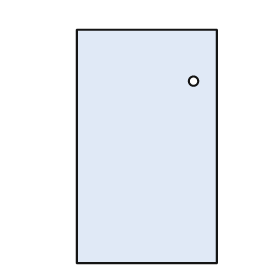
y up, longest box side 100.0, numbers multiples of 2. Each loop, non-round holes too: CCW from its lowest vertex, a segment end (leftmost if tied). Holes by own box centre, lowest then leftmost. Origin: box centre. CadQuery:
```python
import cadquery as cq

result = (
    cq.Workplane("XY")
    .moveTo(-30.0, -50.0)
    .lineTo(30.0, -50.0)
    .lineTo(30.0, 50.0)
    .lineTo(-30.0, 50.0)
    .close()
    .moveTo(20.0, 28.0)
    .circle(2.0)
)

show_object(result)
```